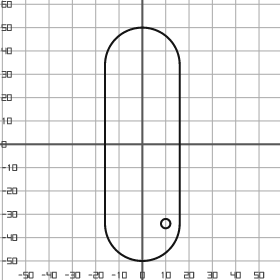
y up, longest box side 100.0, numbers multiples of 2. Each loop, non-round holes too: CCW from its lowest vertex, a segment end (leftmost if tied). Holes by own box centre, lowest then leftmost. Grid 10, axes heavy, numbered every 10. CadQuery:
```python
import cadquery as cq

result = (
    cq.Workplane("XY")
    .moveTo(-16.0, -34.0)
    .threePointArc((0.0, -50.0), (16.0, -34.0))
    .lineTo(16.0, 34.0)
    .threePointArc((0.0, 50.0), (-16.0, 34.0))
    .close()
    .moveTo(10.0, -34.0)
    .circle(2.0)
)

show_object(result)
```